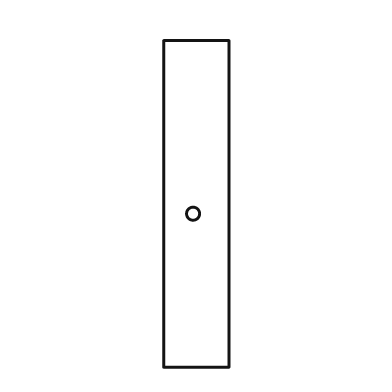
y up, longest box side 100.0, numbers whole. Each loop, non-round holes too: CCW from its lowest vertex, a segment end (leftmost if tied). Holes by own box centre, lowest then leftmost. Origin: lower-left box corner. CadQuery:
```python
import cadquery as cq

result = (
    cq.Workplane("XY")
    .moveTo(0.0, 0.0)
    .lineTo(20.0, 0.0)
    .lineTo(20.0, 100.0)
    .lineTo(0.0, 100.0)
    .close()
    .moveTo(9.0, 47.0)
    .circle(2.0)
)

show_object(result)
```